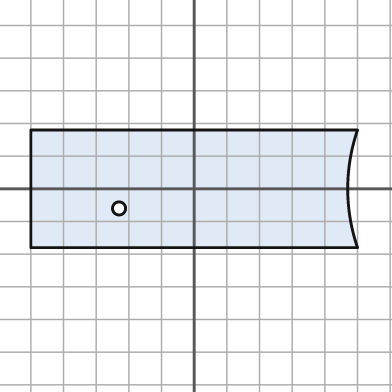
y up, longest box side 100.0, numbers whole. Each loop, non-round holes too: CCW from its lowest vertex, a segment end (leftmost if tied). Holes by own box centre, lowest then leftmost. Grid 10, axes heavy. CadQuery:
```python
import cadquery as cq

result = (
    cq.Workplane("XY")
    .moveTo(-50.0, -18.0)
    .lineTo(50.0, -18.0)
    .threePointArc((47.0, 0.0), (50.0, 18.0))
    .lineTo(-50.0, 18.0)
    .close()
    .moveTo(-23.0, -6.0)
    .circle(2.0)
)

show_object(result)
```